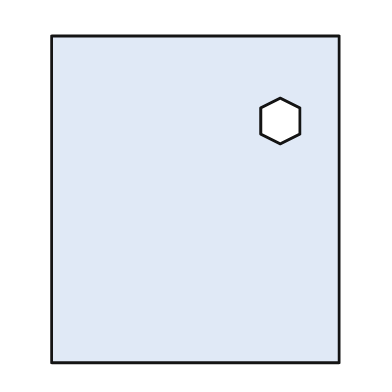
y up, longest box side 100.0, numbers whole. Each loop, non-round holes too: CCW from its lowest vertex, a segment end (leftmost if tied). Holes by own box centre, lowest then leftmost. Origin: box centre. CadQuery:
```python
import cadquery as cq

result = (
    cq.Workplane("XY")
    .moveTo(-44.0, -50.0)
    .lineTo(44.0, -50.0)
    .lineTo(44.0, 50.0)
    .lineTo(-44.0, 50.0)
    .close()
    .moveTo(26.0, 17.0)
    .lineTo(32.0, 20.0)
    .lineTo(32.0, 28.0)
    .lineTo(26.0, 31.0)
    .lineTo(20.0, 28.0)
    .lineTo(20.0, 20.0)
    .close()
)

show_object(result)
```